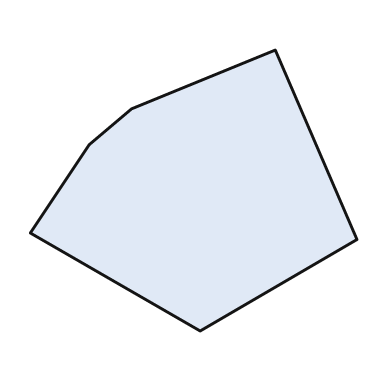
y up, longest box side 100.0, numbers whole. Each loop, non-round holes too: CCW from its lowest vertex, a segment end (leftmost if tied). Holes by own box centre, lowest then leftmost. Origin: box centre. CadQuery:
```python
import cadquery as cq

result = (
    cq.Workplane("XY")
    .moveTo(2.0, -43.0)
    .lineTo(50.0, -15.0)
    .lineTo(25.0, 43.0)
    .lineTo(-19.0, 25.0)
    .lineTo(-32.0, 14.0)
    .lineTo(-50.0, -13.0)
    .close()
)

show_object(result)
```